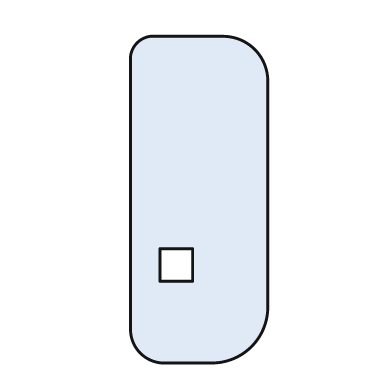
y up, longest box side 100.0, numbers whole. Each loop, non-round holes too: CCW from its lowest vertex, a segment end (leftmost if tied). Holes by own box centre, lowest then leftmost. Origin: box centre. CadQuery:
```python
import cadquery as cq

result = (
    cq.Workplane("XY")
    .moveTo(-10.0, -50.0)
    .lineTo(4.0, -50.0)
    .threePointArc((16.0, -45.0), (21.0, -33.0))
    .lineTo(21.0, 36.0)
    .threePointArc((17.0, 46.0), (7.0, 50.0))
    .lineTo(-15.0, 50.0)
    .threePointArc((-19.0, 48.0), (-21.0, 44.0))
    .lineTo(-21.0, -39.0)
    .threePointArc((-18.0, -47.0), (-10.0, -50.0))
    .close()
    .moveTo(-12.0, -25.0)
    .lineTo(-2.0, -25.0)
    .lineTo(-2.0, -15.0)
    .lineTo(-12.0, -15.0)
    .close()
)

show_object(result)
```